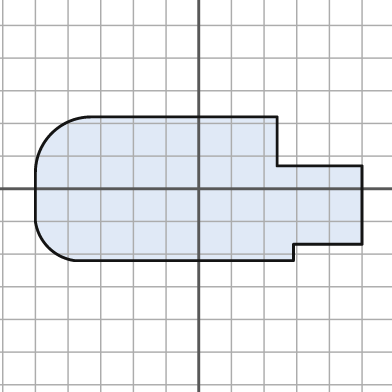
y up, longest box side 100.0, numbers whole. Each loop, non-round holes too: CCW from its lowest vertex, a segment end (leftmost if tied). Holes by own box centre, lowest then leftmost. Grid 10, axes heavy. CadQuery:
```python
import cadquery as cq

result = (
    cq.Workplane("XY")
    .moveTo(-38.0, -22.0)
    .lineTo(29.0, -22.0)
    .lineTo(29.0, -17.0)
    .lineTo(50.0, -17.0)
    .lineTo(50.0, 7.0)
    .lineTo(24.0, 7.0)
    .lineTo(24.0, 22.0)
    .lineTo(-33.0, 22.0)
    .threePointArc((-45.0, 17.0), (-50.0, 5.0))
    .lineTo(-50.0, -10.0)
    .threePointArc((-46.0, -18.0), (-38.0, -22.0))
    .close()
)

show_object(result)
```